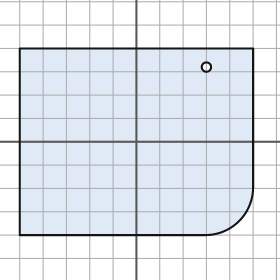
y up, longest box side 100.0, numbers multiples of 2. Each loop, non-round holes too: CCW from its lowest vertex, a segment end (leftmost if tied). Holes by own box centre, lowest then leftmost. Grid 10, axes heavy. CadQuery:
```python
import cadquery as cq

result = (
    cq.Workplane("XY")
    .moveTo(-50.0, -40.0)
    .lineTo(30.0, -40.0)
    .threePointArc((44.0, -34.0), (50.0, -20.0))
    .lineTo(50.0, 40.0)
    .lineTo(-50.0, 40.0)
    .close()
    .moveTo(30.0, 32.0)
    .circle(2.0)
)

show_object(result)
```